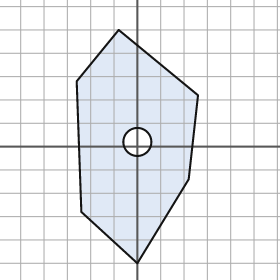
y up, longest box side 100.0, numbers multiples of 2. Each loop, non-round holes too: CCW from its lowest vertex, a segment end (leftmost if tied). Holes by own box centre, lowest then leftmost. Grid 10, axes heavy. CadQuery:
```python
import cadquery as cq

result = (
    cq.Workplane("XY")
    .moveTo(0.0, -50.0)
    .lineTo(22.0, -14.0)
    .lineTo(26.0, 22.0)
    .lineTo(-8.0, 50.0)
    .lineTo(-26.0, 28.0)
    .lineTo(-24.0, -28.0)
    .close()
    .moveTo(0.0, 2.0)
    .circle(6.0)
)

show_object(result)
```